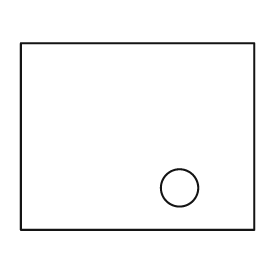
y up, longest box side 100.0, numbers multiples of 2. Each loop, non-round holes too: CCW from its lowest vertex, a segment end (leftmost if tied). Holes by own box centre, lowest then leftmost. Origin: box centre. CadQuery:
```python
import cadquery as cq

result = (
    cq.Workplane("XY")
    .moveTo(-50.0, -40.0)
    .lineTo(50.0, -40.0)
    .lineTo(50.0, 40.0)
    .lineTo(-50.0, 40.0)
    .close()
    .moveTo(18.0, -22.0)
    .circle(8.0)
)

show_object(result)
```